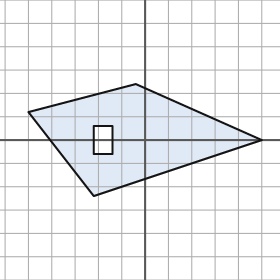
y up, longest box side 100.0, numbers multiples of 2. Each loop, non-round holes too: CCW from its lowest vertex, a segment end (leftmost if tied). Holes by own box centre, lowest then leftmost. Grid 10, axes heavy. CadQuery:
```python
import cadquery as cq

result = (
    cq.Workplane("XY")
    .moveTo(-22.0, -24.0)
    .lineTo(50.0, 0.0)
    .lineTo(-4.0, 24.0)
    .lineTo(-50.0, 12.0)
    .close()
    .moveTo(-22.0, -6.0)
    .lineTo(-14.0, -6.0)
    .lineTo(-14.0, 6.0)
    .lineTo(-22.0, 6.0)
    .close()
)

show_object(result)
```